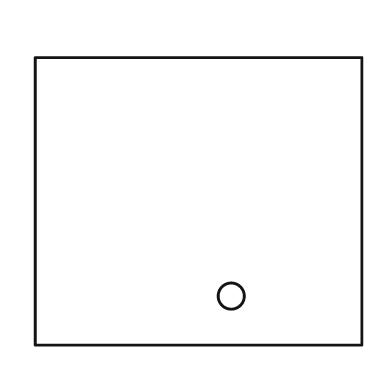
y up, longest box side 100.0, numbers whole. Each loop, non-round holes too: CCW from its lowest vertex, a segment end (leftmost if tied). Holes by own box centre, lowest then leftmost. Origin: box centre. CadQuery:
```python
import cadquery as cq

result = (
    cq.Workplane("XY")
    .moveTo(-50.0, -44.0)
    .lineTo(50.0, -44.0)
    .lineTo(50.0, 44.0)
    .lineTo(-50.0, 44.0)
    .close()
    .moveTo(10.0, -29.0)
    .circle(4.0)
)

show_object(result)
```